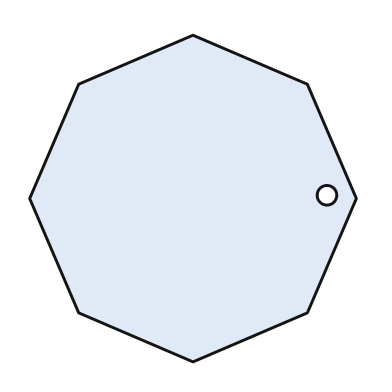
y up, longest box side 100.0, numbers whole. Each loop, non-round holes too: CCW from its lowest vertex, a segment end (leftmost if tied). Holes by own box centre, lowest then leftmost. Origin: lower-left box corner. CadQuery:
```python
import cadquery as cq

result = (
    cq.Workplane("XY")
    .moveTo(50.0, 0.0)
    .lineTo(85.0, 15.0)
    .lineTo(100.0, 50.0)
    .lineTo(85.0, 85.0)
    .lineTo(50.0, 100.0)
    .lineTo(15.0, 85.0)
    .lineTo(0.0, 50.0)
    .lineTo(15.0, 15.0)
    .close()
    .moveTo(91.0, 51.0)
    .circle(3.0)
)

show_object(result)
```